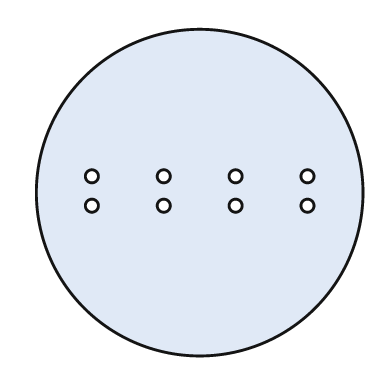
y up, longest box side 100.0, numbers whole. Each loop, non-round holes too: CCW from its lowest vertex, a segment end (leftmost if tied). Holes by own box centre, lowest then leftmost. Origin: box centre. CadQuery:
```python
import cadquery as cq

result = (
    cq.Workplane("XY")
    .moveTo(0.0, 0.0)
    .circle(50.0)
    .moveTo(-33.0, -4.0)
    .circle(2.0)
    .moveTo(-11.0, -4.0)
    .circle(2.0)
    .moveTo(11.0, -4.0)
    .circle(2.0)
    .moveTo(33.0, -4.0)
    .circle(2.0)
    .moveTo(-33.0, 5.0)
    .circle(2.0)
    .moveTo(-11.0, 5.0)
    .circle(2.0)
    .moveTo(11.0, 5.0)
    .circle(2.0)
    .moveTo(33.0, 5.0)
    .circle(2.0)
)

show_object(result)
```